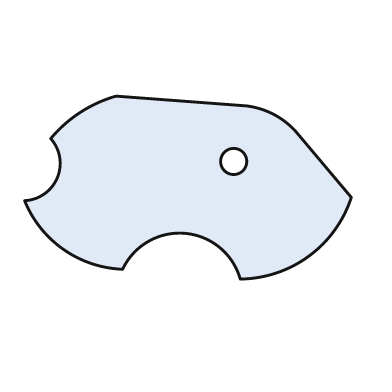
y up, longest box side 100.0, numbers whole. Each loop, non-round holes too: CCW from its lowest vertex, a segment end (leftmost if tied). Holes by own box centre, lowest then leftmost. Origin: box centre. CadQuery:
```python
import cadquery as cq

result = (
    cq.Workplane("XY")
    .moveTo(16.0, -28.0)
    .threePointArc((37.0, -21.0), (50.0, -3.0))
    .lineTo(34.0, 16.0)
    .threePointArc((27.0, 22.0), (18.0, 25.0))
    .lineTo(-22.0, 28.0)
    .threePointArc((-33.0, 23.0), (-42.0, 15.0))
    .threePointArc((-40.0, 3.0), (-50.0, -4.0))
    .threePointArc((-38.0, -19.0), (-20.0, -25.0))
    .threePointArc((-1.0, -14.0), (16.0, -28.0))
    .close()
    .moveTo(14.0, 8.0)
    .circle(4.0)
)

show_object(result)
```